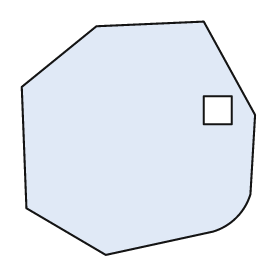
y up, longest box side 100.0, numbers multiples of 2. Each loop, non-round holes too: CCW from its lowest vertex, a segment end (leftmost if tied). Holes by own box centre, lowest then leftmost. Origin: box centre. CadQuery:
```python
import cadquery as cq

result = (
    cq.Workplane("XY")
    .moveTo(-14.0, -50.0)
    .lineTo(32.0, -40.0)
    .threePointArc((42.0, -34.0), (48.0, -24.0))
    .lineTo(50.0, 10.0)
    .lineTo(28.0, 50.0)
    .lineTo(-18.0, 48.0)
    .lineTo(-50.0, 22.0)
    .lineTo(-48.0, -30.0)
    .close()
    .moveTo(28.0, 6.0)
    .lineTo(40.0, 6.0)
    .lineTo(40.0, 18.0)
    .lineTo(28.0, 18.0)
    .close()
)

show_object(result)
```